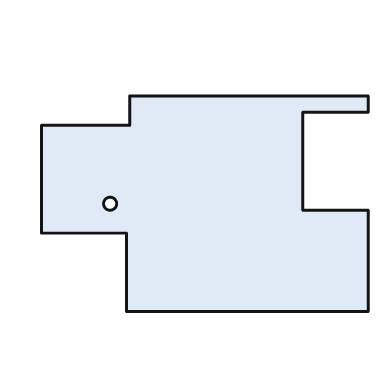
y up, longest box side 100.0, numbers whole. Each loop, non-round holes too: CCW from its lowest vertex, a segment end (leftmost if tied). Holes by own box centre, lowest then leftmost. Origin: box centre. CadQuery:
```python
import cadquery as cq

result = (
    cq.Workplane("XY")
    .moveTo(-24.0, -33.0)
    .lineTo(50.0, -33.0)
    .lineTo(50.0, -2.0)
    .lineTo(30.0, -2.0)
    .lineTo(30.0, 28.0)
    .lineTo(50.0, 28.0)
    .lineTo(50.0, 33.0)
    .lineTo(-23.0, 33.0)
    .lineTo(-23.0, 24.0)
    .lineTo(-50.0, 24.0)
    .lineTo(-50.0, -9.0)
    .lineTo(-24.0, -9.0)
    .close()
    .moveTo(-29.0, 0.0)
    .circle(2.0)
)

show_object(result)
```